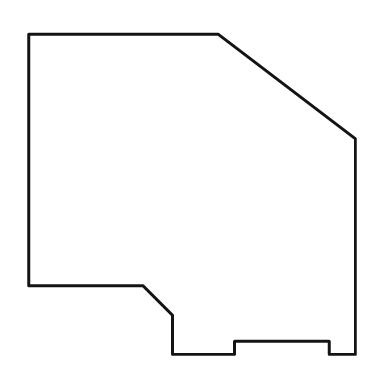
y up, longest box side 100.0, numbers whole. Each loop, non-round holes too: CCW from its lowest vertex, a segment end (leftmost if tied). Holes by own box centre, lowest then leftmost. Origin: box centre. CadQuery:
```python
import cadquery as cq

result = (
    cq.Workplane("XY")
    .moveTo(-6.0, -49.0)
    .lineTo(13.0, -49.0)
    .lineTo(13.0, -45.0)
    .lineTo(42.0, -45.0)
    .lineTo(42.0, -49.0)
    .lineTo(50.0, -49.0)
    .lineTo(50.0, 17.0)
    .lineTo(8.0, 49.0)
    .lineTo(-50.0, 49.0)
    .lineTo(-50.0, -28.0)
    .lineTo(-15.0, -28.0)
    .lineTo(-6.0, -37.0)
    .close()
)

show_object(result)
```